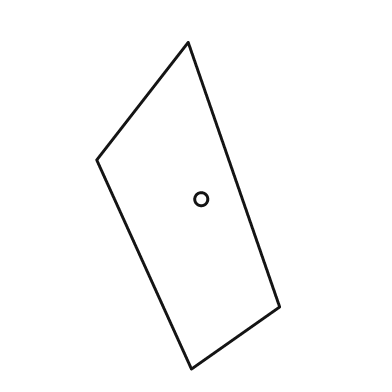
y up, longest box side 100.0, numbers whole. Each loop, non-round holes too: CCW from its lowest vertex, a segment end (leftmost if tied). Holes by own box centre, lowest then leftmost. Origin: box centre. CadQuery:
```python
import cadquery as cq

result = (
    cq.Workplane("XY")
    .moveTo(1.0, -50.0)
    .lineTo(28.0, -31.0)
    .lineTo(0.0, 50.0)
    .lineTo(-28.0, 14.0)
    .close()
    .moveTo(4.0, 2.0)
    .circle(2.0)
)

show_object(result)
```